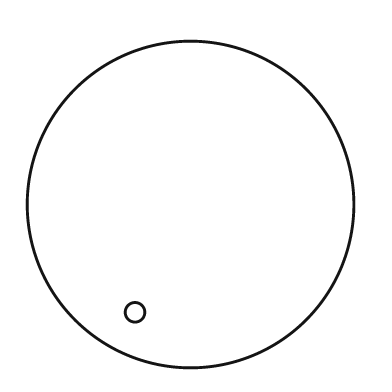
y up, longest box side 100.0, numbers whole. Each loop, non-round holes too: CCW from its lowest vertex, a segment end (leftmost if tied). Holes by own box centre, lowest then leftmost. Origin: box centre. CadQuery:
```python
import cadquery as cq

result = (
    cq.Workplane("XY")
    .moveTo(0.0, 0.0)
    .circle(50.0)
    .moveTo(-17.0, -33.0)
    .circle(3.0)
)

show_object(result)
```